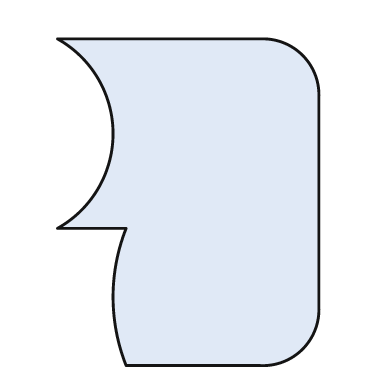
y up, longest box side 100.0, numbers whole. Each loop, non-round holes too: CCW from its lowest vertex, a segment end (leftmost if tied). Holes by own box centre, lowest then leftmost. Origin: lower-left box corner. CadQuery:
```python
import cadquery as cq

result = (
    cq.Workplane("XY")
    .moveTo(21.0, 0.0)
    .lineTo(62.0, 0.0)
    .threePointArc((75.0, 5.0), (80.0, 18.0))
    .lineTo(80.0, 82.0)
    .threePointArc((75.0, 95.0), (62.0, 100.0))
    .lineTo(0.0, 100.0)
    .threePointArc((17.0, 71.0), (0.0, 42.0))
    .lineTo(21.0, 42.0)
    .threePointArc((17.0, 21.0), (21.0, 0.0))
    .close()
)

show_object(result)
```